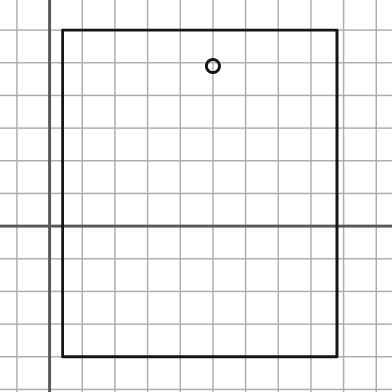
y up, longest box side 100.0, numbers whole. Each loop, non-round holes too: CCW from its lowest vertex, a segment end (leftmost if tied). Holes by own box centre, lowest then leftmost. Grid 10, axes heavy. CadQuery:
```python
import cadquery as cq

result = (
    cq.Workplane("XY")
    .moveTo(4.0, -40.0)
    .lineTo(88.0, -40.0)
    .lineTo(88.0, 60.0)
    .lineTo(4.0, 60.0)
    .close()
    .moveTo(50.0, 49.0)
    .circle(2.0)
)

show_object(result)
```